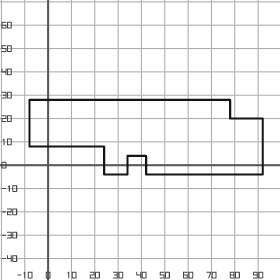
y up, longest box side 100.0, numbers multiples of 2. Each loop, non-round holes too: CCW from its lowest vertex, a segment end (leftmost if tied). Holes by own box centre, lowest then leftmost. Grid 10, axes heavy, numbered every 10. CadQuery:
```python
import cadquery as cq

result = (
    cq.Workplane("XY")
    .moveTo(24.0, -4.0)
    .lineTo(34.0, -4.0)
    .lineTo(34.0, 4.0)
    .lineTo(42.0, 4.0)
    .lineTo(42.0, -4.0)
    .lineTo(92.0, -4.0)
    .lineTo(92.0, 20.0)
    .lineTo(78.0, 20.0)
    .lineTo(78.0, 28.0)
    .lineTo(-8.0, 28.0)
    .lineTo(-8.0, 8.0)
    .lineTo(24.0, 8.0)
    .close()
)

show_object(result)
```